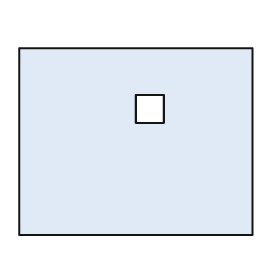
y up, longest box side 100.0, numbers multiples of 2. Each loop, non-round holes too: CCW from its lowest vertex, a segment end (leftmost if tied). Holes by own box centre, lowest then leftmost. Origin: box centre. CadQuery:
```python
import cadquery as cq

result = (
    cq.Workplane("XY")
    .moveTo(-50.0, -40.0)
    .lineTo(50.0, -40.0)
    .lineTo(50.0, 40.0)
    .lineTo(-50.0, 40.0)
    .close()
    .moveTo(0.0, 8.0)
    .lineTo(12.0, 8.0)
    .lineTo(12.0, 20.0)
    .lineTo(0.0, 20.0)
    .close()
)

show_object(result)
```